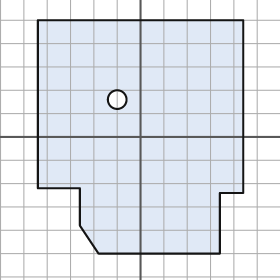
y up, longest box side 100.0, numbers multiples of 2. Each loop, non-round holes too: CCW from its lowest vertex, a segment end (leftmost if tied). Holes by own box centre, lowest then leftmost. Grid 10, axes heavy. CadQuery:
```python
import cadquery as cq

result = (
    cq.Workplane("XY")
    .moveTo(-18.0, -50.0)
    .lineTo(34.0, -50.0)
    .lineTo(34.0, -24.0)
    .lineTo(44.0, -24.0)
    .lineTo(44.0, 50.0)
    .lineTo(-44.0, 50.0)
    .lineTo(-44.0, -22.0)
    .lineTo(-26.0, -22.0)
    .lineTo(-26.0, -38.0)
    .close()
    .moveTo(-10.0, 16.0)
    .circle(4.0)
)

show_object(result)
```